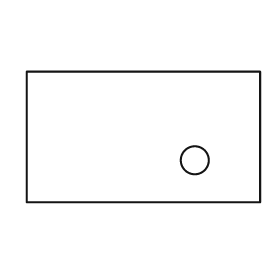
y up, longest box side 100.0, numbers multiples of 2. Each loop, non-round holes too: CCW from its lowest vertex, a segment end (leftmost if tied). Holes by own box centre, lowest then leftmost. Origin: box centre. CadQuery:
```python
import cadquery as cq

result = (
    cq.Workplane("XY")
    .moveTo(-50.0, -28.0)
    .lineTo(50.0, -28.0)
    .lineTo(50.0, 28.0)
    .lineTo(-50.0, 28.0)
    .close()
    .moveTo(22.0, -10.0)
    .circle(6.0)
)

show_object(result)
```